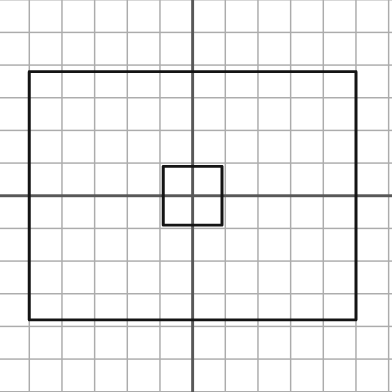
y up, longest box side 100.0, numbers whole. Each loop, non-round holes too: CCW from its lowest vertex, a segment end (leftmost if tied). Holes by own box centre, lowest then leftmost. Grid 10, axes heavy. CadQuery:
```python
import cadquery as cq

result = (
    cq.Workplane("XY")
    .moveTo(-50.0, -38.0)
    .lineTo(50.0, -38.0)
    .lineTo(50.0, 38.0)
    .lineTo(-50.0, 38.0)
    .close()
    .moveTo(-9.0, -9.0)
    .lineTo(9.0, -9.0)
    .lineTo(9.0, 9.0)
    .lineTo(-9.0, 9.0)
    .close()
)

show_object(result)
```